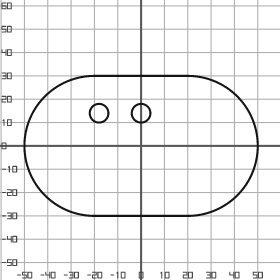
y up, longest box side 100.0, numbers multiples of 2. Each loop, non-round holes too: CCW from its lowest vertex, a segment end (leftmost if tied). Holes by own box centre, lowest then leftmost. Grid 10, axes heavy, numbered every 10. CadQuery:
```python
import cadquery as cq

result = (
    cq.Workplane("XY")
    .moveTo(-20.0, -30.0)
    .lineTo(20.0, -30.0)
    .threePointArc((50.0, 0.0), (20.0, 30.0))
    .lineTo(-20.0, 30.0)
    .threePointArc((-50.0, 0.0), (-20.0, -30.0))
    .close()
    .moveTo(-18.0, 14.0)
    .circle(4.0)
    .moveTo(0.0, 14.0)
    .circle(4.0)
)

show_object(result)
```